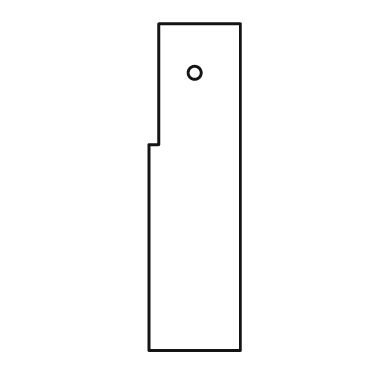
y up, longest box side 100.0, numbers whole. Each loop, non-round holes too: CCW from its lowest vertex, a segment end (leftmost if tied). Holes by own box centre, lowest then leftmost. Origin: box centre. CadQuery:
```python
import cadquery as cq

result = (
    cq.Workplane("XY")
    .moveTo(-14.0, -50.0)
    .lineTo(14.0, -50.0)
    .lineTo(14.0, 50.0)
    .lineTo(-11.0, 50.0)
    .lineTo(-11.0, 13.0)
    .lineTo(-14.0, 13.0)
    .close()
    .moveTo(0.0, 35.0)
    .circle(2.0)
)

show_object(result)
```